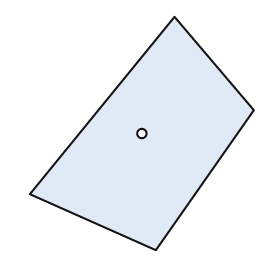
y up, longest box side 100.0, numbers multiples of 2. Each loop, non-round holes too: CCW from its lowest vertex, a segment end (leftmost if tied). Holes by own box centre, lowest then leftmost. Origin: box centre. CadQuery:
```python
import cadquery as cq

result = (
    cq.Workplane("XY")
    .moveTo(6.0, -50.0)
    .lineTo(48.0, 10.0)
    .lineTo(14.0, 50.0)
    .lineTo(-48.0, -26.0)
    .close()
    .moveTo(0.0, 0.0)
    .circle(2.0)
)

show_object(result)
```